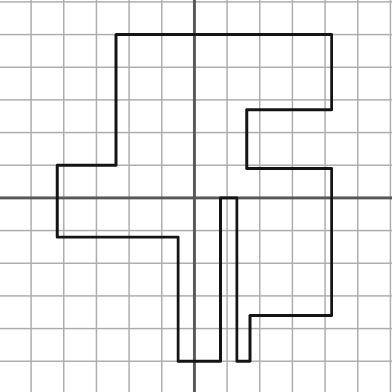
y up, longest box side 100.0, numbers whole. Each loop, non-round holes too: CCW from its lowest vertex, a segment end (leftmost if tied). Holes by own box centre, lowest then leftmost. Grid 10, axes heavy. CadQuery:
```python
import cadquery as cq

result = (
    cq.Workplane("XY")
    .moveTo(-5.0, -50.0)
    .lineTo(8.0, -50.0)
    .lineTo(8.0, 0.0)
    .lineTo(13.0, 0.0)
    .lineTo(13.0, -50.0)
    .lineTo(17.0, -50.0)
    .lineTo(17.0, -36.0)
    .lineTo(42.0, -36.0)
    .lineTo(42.0, 9.0)
    .lineTo(16.0, 9.0)
    .lineTo(16.0, 27.0)
    .lineTo(42.0, 27.0)
    .lineTo(42.0, 50.0)
    .lineTo(-24.0, 50.0)
    .lineTo(-24.0, 10.0)
    .lineTo(-42.0, 10.0)
    .lineTo(-42.0, -12.0)
    .lineTo(-5.0, -12.0)
    .close()
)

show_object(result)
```